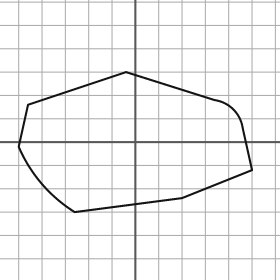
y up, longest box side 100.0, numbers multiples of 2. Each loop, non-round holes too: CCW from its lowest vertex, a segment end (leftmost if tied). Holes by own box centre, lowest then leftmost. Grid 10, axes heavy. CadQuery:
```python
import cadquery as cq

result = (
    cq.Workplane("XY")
    .moveTo(-26.0, -30.0)
    .lineTo(20.0, -24.0)
    .lineTo(50.0, -12.0)
    .lineTo(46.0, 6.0)
    .threePointArc((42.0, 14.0), (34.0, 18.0))
    .lineTo(-4.0, 30.0)
    .lineTo(-46.0, 16.0)
    .lineTo(-50.0, -2.0)
    .threePointArc((-40.0, -18.0), (-26.0, -30.0))
    .close()
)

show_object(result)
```